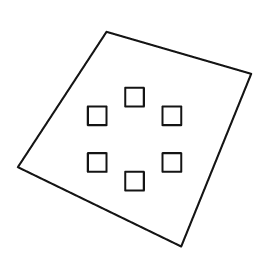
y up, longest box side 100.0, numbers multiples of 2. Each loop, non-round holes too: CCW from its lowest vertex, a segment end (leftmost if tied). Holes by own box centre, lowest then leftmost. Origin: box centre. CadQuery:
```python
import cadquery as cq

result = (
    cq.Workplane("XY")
    .moveTo(20.0, -46.0)
    .lineTo(50.0, 28.0)
    .lineTo(-12.0, 46.0)
    .lineTo(-50.0, -12.0)
    .close()
    .moveTo(-4.0, -22.0)
    .lineTo(4.0, -22.0)
    .lineTo(4.0, -14.0)
    .lineTo(-4.0, -14.0)
    .close()
    .moveTo(-20.0, -14.0)
    .lineTo(-12.0, -14.0)
    .lineTo(-12.0, -6.0)
    .lineTo(-20.0, -6.0)
    .close()
    .moveTo(12.0, -14.0)
    .lineTo(20.0, -14.0)
    .lineTo(20.0, -6.0)
    .lineTo(12.0, -6.0)
    .close()
    .moveTo(-20.0, 6.0)
    .lineTo(-12.0, 6.0)
    .lineTo(-12.0, 14.0)
    .lineTo(-20.0, 14.0)
    .close()
    .moveTo(12.0, 6.0)
    .lineTo(20.0, 6.0)
    .lineTo(20.0, 14.0)
    .lineTo(12.0, 14.0)
    .close()
    .moveTo(-4.0, 14.0)
    .lineTo(4.0, 14.0)
    .lineTo(4.0, 22.0)
    .lineTo(-4.0, 22.0)
    .close()
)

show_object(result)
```